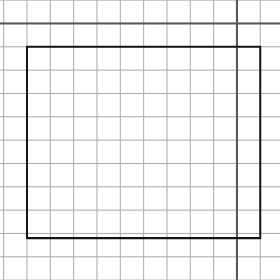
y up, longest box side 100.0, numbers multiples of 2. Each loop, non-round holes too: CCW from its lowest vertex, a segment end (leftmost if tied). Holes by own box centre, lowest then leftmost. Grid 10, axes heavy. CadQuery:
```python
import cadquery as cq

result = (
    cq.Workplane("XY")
    .moveTo(-90.0, -92.0)
    .lineTo(10.0, -92.0)
    .lineTo(10.0, -10.0)
    .lineTo(-90.0, -10.0)
    .close()
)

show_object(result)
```